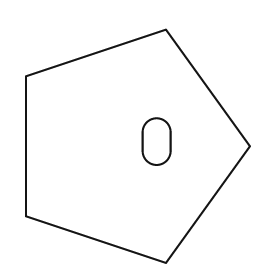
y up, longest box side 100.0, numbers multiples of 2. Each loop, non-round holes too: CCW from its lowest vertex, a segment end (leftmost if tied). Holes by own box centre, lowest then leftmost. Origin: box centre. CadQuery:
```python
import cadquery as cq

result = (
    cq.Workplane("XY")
    .moveTo(12.0, -50.0)
    .lineTo(48.0, 0.0)
    .lineTo(12.0, 50.0)
    .lineTo(-48.0, 30.0)
    .lineTo(-48.0, -30.0)
    .close()
    .moveTo(2.0, -2.0)
    .threePointArc((8.0, -8.0), (14.0, -2.0))
    .lineTo(14.0, 6.0)
    .threePointArc((8.0, 12.0), (2.0, 6.0))
    .close()
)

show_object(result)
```